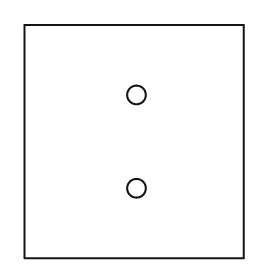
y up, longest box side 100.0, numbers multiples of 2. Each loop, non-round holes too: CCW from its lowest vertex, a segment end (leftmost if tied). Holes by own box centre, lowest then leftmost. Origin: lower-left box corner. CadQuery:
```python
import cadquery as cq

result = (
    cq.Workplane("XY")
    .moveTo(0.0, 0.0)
    .lineTo(94.0, 0.0)
    .lineTo(94.0, 100.0)
    .lineTo(0.0, 100.0)
    .close()
    .moveTo(48.0, 30.0)
    .circle(4.0)
    .moveTo(48.0, 70.0)
    .circle(4.0)
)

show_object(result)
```